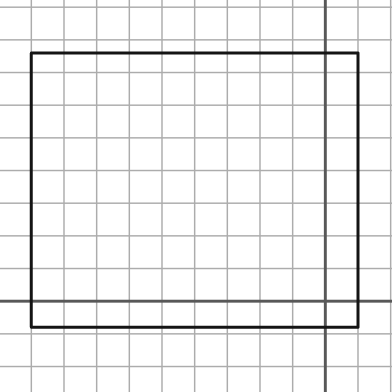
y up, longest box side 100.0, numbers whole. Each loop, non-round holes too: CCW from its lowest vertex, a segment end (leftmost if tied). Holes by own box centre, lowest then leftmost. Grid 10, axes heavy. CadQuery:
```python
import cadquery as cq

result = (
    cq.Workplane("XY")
    .moveTo(-90.0, -8.0)
    .lineTo(10.0, -8.0)
    .lineTo(10.0, 76.0)
    .lineTo(-90.0, 76.0)
    .close()
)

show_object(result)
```